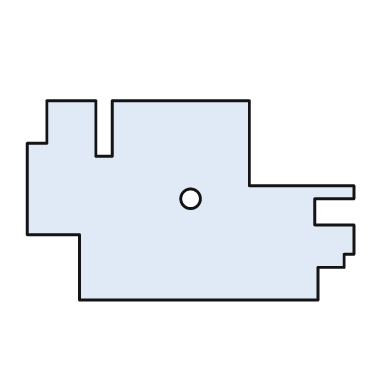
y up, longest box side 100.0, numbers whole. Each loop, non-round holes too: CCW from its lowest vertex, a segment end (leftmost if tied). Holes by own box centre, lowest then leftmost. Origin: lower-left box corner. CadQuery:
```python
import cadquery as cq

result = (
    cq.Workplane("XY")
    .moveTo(16.0, 0.0)
    .lineTo(89.0, 0.0)
    .lineTo(89.0, 10.0)
    .lineTo(97.0, 10.0)
    .lineTo(97.0, 14.0)
    .lineTo(100.0, 14.0)
    .lineTo(100.0, 23.0)
    .lineTo(88.0, 23.0)
    .lineTo(88.0, 31.0)
    .lineTo(100.0, 31.0)
    .lineTo(100.0, 35.0)
    .lineTo(68.0, 35.0)
    .lineTo(68.0, 61.0)
    .lineTo(26.0, 61.0)
    .lineTo(26.0, 44.0)
    .lineTo(21.0, 44.0)
    .lineTo(21.0, 61.0)
    .lineTo(6.0, 61.0)
    .lineTo(6.0, 48.0)
    .lineTo(0.0, 48.0)
    .lineTo(0.0, 20.0)
    .lineTo(16.0, 20.0)
    .close()
    .moveTo(50.0, 31.0)
    .circle(3.0)
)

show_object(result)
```